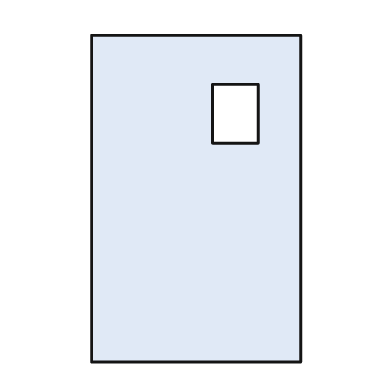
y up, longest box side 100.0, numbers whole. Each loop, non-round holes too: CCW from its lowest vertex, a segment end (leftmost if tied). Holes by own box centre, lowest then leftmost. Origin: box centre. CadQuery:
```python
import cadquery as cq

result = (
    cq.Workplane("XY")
    .moveTo(-32.0, -50.0)
    .lineTo(32.0, -50.0)
    .lineTo(32.0, 50.0)
    .lineTo(-32.0, 50.0)
    .close()
    .moveTo(5.0, 17.0)
    .lineTo(19.0, 17.0)
    .lineTo(19.0, 35.0)
    .lineTo(5.0, 35.0)
    .close()
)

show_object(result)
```